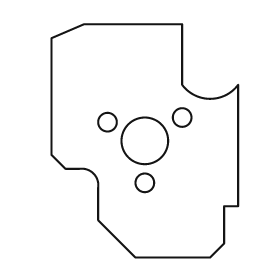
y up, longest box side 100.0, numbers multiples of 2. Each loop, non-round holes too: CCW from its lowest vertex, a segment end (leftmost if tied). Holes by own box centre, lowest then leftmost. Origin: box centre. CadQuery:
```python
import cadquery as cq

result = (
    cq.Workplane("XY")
    .moveTo(-4.0, -50.0)
    .lineTo(28.0, -50.0)
    .lineTo(34.0, -44.0)
    .lineTo(34.0, -28.0)
    .lineTo(40.0, -28.0)
    .lineTo(40.0, 24.0)
    .threePointArc((28.0, 18.0), (16.0, 24.0))
    .lineTo(16.0, 50.0)
    .lineTo(-26.0, 50.0)
    .lineTo(-40.0, 44.0)
    .lineTo(-40.0, -6.0)
    .lineTo(-34.0, -12.0)
    .lineTo(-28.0, -12.0)
    .threePointArc((-22.0, -14.0), (-20.0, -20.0))
    .lineTo(-20.0, -34.0)
    .close()
    .moveTo(0.0, -18.0)
    .circle(4.0)
    .moveTo(0.0, 0.0)
    .circle(10.0)
    .moveTo(-16.0, 8.0)
    .circle(4.0)
    .moveTo(16.0, 10.0)
    .circle(4.0)
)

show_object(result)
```